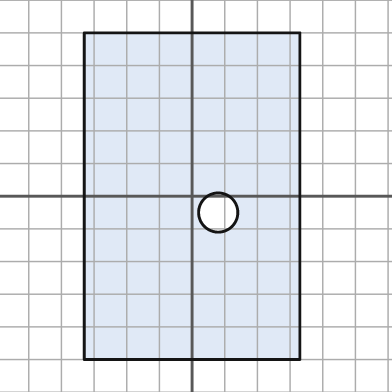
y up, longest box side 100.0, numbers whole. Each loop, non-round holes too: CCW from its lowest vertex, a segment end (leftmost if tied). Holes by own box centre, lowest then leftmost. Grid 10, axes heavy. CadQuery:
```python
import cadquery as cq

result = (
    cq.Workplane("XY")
    .moveTo(-33.0, -50.0)
    .lineTo(33.0, -50.0)
    .lineTo(33.0, 50.0)
    .lineTo(-33.0, 50.0)
    .close()
    .moveTo(8.0, -5.0)
    .circle(6.0)
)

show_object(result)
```